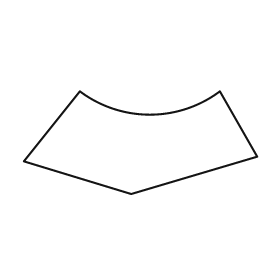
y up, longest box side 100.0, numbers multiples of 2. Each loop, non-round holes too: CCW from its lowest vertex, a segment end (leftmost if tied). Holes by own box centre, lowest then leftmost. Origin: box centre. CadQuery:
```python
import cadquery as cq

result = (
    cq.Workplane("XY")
    .moveTo(-4.0, -22.0)
    .lineTo(50.0, -6.0)
    .lineTo(34.0, 22.0)
    .threePointArc((4.0, 12.0), (-26.0, 22.0))
    .lineTo(-50.0, -8.0)
    .close()
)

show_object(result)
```